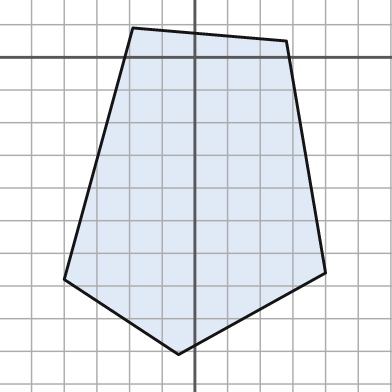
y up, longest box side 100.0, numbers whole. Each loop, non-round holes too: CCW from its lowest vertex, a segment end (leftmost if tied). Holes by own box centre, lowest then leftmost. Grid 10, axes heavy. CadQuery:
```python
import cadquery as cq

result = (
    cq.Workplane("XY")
    .moveTo(-5.0, -91.0)
    .lineTo(40.0, -66.0)
    .lineTo(28.0, 5.0)
    .lineTo(-19.0, 9.0)
    .lineTo(-40.0, -68.0)
    .close()
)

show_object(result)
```